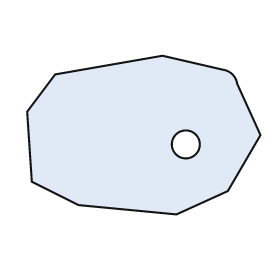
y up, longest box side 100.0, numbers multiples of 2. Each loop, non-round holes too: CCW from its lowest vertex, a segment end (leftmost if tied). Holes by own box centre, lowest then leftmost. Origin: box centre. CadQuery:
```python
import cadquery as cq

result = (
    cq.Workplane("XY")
    .moveTo(14.0, -34.0)
    .lineTo(36.0, -24.0)
    .lineTo(50.0, 0.0)
    .lineTo(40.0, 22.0)
    .threePointArc((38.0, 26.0), (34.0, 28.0))
    .lineTo(8.0, 34.0)
    .lineTo(-38.0, 26.0)
    .lineTo(-50.0, 10.0)
    .lineTo(-48.0, -20.0)
    .lineTo(-28.0, -30.0)
    .close()
    .moveTo(18.0, -4.0)
    .circle(6.0)
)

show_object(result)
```